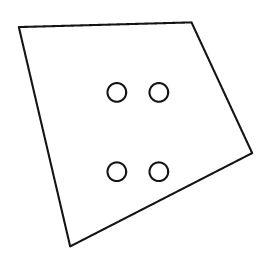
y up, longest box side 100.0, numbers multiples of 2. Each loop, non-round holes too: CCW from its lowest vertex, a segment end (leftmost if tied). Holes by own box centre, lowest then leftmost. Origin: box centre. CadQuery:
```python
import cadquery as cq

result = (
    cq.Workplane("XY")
    .moveTo(-28.0, -48.0)
    .lineTo(50.0, -8.0)
    .lineTo(24.0, 48.0)
    .lineTo(-50.0, 46.0)
    .close()
    .moveTo(-8.0, -16.0)
    .circle(4.0)
    .moveTo(10.0, -16.0)
    .circle(4.0)
    .moveTo(-8.0, 18.0)
    .circle(4.0)
    .moveTo(10.0, 18.0)
    .circle(4.0)
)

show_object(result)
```